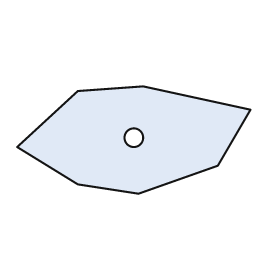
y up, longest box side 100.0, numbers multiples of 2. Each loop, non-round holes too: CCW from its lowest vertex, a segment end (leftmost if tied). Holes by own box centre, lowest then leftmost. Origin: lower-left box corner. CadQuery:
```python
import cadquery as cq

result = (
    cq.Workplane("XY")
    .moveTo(52.0, 0.0)
    .lineTo(86.0, 12.0)
    .lineTo(100.0, 36.0)
    .lineTo(54.0, 46.0)
    .lineTo(26.0, 44.0)
    .lineTo(0.0, 20.0)
    .lineTo(26.0, 4.0)
    .close()
    .moveTo(50.0, 24.0)
    .circle(4.0)
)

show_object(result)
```